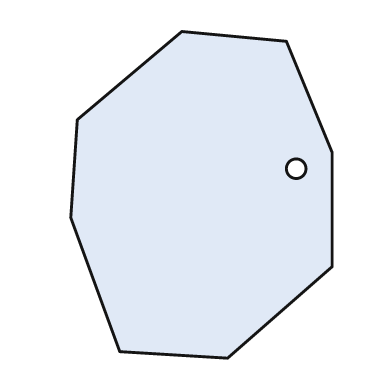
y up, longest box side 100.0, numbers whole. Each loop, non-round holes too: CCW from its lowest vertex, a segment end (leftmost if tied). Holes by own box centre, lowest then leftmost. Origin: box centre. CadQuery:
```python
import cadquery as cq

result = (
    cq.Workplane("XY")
    .moveTo(8.0, -50.0)
    .lineTo(40.0, -22.0)
    .lineTo(40.0, 13.0)
    .lineTo(26.0, 47.0)
    .lineTo(-6.0, 50.0)
    .lineTo(-38.0, 23.0)
    .lineTo(-40.0, -7.0)
    .lineTo(-25.0, -48.0)
    .close()
    .moveTo(29.0, 8.0)
    .circle(3.0)
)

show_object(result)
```